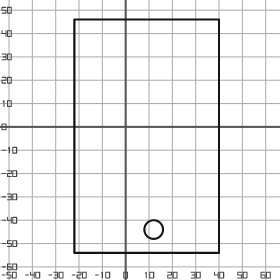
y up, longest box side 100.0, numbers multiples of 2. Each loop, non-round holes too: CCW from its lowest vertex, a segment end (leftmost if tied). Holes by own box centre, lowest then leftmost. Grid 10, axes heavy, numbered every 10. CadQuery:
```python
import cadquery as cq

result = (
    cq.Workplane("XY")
    .moveTo(-22.0, -54.0)
    .lineTo(40.0, -54.0)
    .lineTo(40.0, 46.0)
    .lineTo(-22.0, 46.0)
    .close()
    .moveTo(12.0, -44.0)
    .circle(4.0)
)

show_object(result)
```